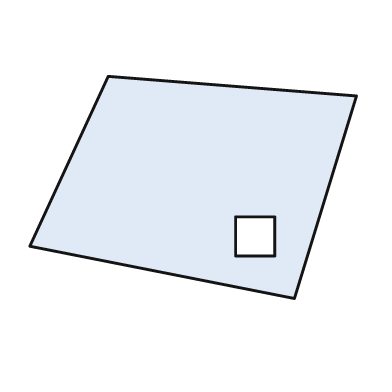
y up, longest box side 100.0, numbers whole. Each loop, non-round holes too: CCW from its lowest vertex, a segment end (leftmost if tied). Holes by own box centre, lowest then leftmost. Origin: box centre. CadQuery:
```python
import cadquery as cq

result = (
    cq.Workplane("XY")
    .moveTo(31.0, -34.0)
    .lineTo(50.0, 28.0)
    .lineTo(-26.0, 34.0)
    .lineTo(-50.0, -18.0)
    .close()
    .moveTo(13.0, -21.0)
    .lineTo(25.0, -21.0)
    .lineTo(25.0, -9.0)
    .lineTo(13.0, -9.0)
    .close()
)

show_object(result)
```